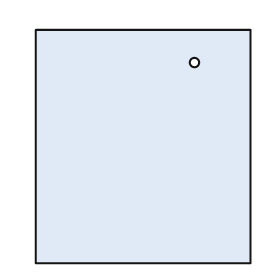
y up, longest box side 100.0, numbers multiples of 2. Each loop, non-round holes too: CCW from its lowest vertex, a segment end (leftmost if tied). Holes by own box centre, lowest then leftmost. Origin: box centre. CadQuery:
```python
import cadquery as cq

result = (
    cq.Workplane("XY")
    .moveTo(-46.0, -50.0)
    .lineTo(46.0, -50.0)
    .lineTo(46.0, 50.0)
    .lineTo(-46.0, 50.0)
    .close()
    .moveTo(22.0, 36.0)
    .circle(2.0)
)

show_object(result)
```